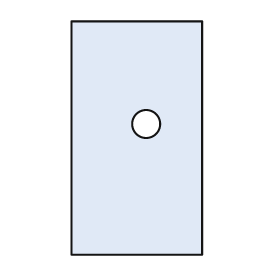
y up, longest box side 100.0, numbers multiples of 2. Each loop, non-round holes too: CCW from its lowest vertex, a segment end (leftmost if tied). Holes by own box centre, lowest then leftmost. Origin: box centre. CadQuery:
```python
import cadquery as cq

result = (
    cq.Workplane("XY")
    .moveTo(-28.0, -50.0)
    .lineTo(28.0, -50.0)
    .lineTo(28.0, 50.0)
    .lineTo(-28.0, 50.0)
    .close()
    .moveTo(4.0, 6.0)
    .circle(6.0)
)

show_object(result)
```